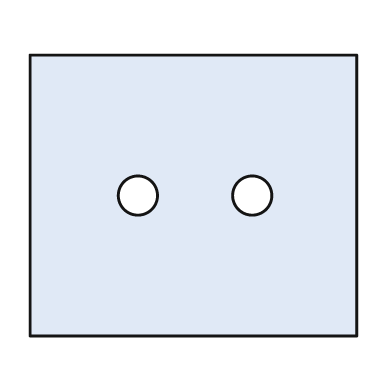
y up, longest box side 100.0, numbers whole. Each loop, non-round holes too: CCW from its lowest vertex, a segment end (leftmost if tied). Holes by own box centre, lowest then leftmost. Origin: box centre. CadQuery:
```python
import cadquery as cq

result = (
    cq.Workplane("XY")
    .moveTo(-50.0, -43.0)
    .lineTo(50.0, -43.0)
    .lineTo(50.0, 43.0)
    .lineTo(-50.0, 43.0)
    .close()
    .moveTo(-17.0, 0.0)
    .circle(6.0)
    .moveTo(18.0, 0.0)
    .circle(6.0)
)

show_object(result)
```